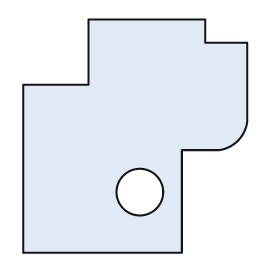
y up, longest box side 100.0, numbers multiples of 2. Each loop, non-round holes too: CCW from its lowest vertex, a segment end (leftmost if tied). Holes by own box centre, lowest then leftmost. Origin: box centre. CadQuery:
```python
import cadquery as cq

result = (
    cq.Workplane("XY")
    .moveTo(-48.0, -50.0)
    .lineTo(20.0, -50.0)
    .lineTo(20.0, -6.0)
    .lineTo(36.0, -6.0)
    .threePointArc((44.0, -2.0), (48.0, 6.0))
    .lineTo(48.0, 40.0)
    .lineTo(30.0, 40.0)
    .lineTo(30.0, 50.0)
    .lineTo(-20.0, 50.0)
    .lineTo(-20.0, 22.0)
    .lineTo(-48.0, 22.0)
    .close()
    .moveTo(2.0, -24.0)
    .circle(10.0)
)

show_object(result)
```